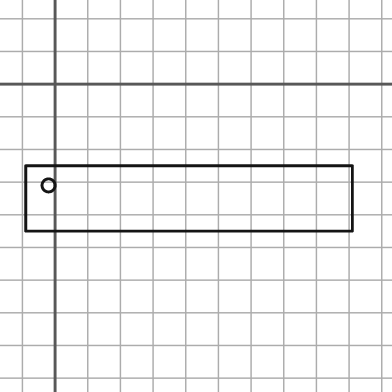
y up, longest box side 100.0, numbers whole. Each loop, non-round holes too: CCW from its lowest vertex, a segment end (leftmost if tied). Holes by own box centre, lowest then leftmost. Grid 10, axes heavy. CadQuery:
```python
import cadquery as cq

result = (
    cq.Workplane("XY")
    .moveTo(-9.0, -45.0)
    .lineTo(91.0, -45.0)
    .lineTo(91.0, -25.0)
    .lineTo(-9.0, -25.0)
    .close()
    .moveTo(-2.0, -31.0)
    .circle(2.0)
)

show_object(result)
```